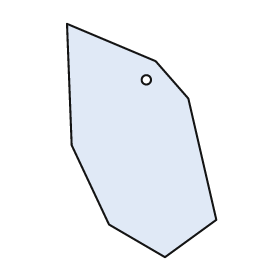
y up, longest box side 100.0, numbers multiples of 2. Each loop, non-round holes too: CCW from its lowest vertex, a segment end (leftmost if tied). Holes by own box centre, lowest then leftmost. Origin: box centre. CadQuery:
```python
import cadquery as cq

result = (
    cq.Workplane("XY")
    .moveTo(10.0, -50.0)
    .lineTo(32.0, -34.0)
    .lineTo(20.0, 18.0)
    .lineTo(6.0, 34.0)
    .lineTo(-32.0, 50.0)
    .lineTo(-30.0, -2.0)
    .lineTo(-14.0, -36.0)
    .close()
    .moveTo(2.0, 26.0)
    .circle(2.0)
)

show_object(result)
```